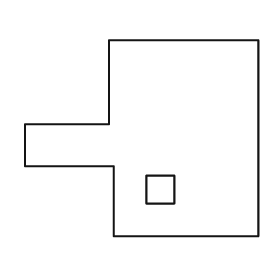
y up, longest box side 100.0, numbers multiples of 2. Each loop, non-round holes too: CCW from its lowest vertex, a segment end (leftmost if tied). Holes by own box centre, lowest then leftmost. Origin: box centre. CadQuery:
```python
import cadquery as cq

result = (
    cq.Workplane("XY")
    .moveTo(-12.0, -42.0)
    .lineTo(50.0, -42.0)
    .lineTo(50.0, 42.0)
    .lineTo(-14.0, 42.0)
    .lineTo(-14.0, 6.0)
    .lineTo(-50.0, 6.0)
    .lineTo(-50.0, -12.0)
    .lineTo(-12.0, -12.0)
    .close()
    .moveTo(2.0, -28.0)
    .lineTo(14.0, -28.0)
    .lineTo(14.0, -16.0)
    .lineTo(2.0, -16.0)
    .close()
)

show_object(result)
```